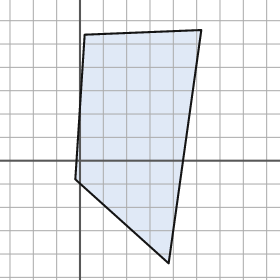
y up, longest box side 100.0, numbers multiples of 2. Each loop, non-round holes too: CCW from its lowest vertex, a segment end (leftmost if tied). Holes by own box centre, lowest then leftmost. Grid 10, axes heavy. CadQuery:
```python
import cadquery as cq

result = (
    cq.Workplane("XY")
    .moveTo(38.0, -44.0)
    .lineTo(52.0, 56.0)
    .lineTo(2.0, 54.0)
    .lineTo(-2.0, -8.0)
    .close()
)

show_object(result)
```